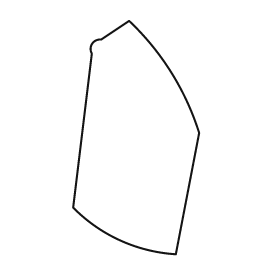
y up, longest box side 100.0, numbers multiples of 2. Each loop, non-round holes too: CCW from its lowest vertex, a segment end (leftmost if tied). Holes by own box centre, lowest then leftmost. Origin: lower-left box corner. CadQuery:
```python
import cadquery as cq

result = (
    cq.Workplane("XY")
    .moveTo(44.0, 0.0)
    .lineTo(54.0, 52.0)
    .threePointArc((42.0, 78.0), (24.0, 100.0))
    .lineTo(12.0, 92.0)
    .threePointArc((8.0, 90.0), (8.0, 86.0))
    .lineTo(0.0, 20.0)
    .threePointArc((20.0, 6.0), (44.0, 0.0))
    .close()
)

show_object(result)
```